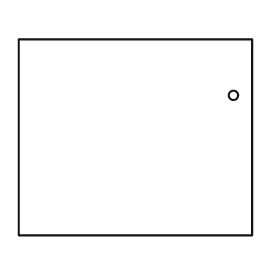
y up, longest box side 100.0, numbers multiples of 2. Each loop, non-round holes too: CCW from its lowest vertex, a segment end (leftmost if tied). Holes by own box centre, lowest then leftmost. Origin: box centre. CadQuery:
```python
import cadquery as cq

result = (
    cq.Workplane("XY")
    .moveTo(-50.0, -42.0)
    .lineTo(50.0, -42.0)
    .lineTo(50.0, 42.0)
    .lineTo(-50.0, 42.0)
    .close()
    .moveTo(42.0, 18.0)
    .circle(2.0)
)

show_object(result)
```